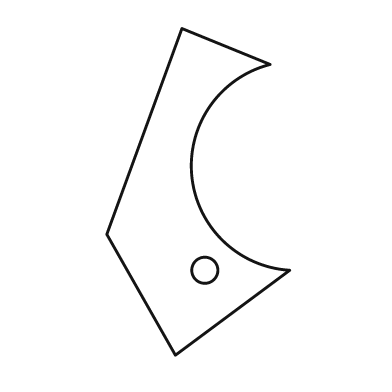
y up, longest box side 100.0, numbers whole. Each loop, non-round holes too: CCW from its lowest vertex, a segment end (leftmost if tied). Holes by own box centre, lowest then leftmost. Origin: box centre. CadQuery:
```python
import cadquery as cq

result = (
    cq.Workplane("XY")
    .moveTo(-7.0, -50.0)
    .lineTo(28.0, -24.0)
    .threePointArc((-2.0, 5.0), (22.0, 39.0))
    .lineTo(-5.0, 50.0)
    .lineTo(-28.0, -13.0)
    .close()
    .moveTo(2.0, -24.0)
    .circle(4.0)
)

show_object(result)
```